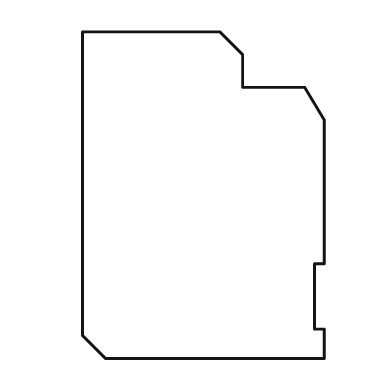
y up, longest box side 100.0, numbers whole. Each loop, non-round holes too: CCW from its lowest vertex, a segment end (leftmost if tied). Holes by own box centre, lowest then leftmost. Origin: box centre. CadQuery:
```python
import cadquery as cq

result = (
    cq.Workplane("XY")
    .moveTo(-30.0, -50.0)
    .lineTo(37.0, -50.0)
    .lineTo(37.0, -41.0)
    .lineTo(34.0, -41.0)
    .lineTo(34.0, -21.0)
    .lineTo(37.0, -21.0)
    .lineTo(37.0, 23.0)
    .lineTo(31.0, 33.0)
    .lineTo(12.0, 33.0)
    .lineTo(12.0, 43.0)
    .lineTo(5.0, 50.0)
    .lineTo(-37.0, 50.0)
    .lineTo(-37.0, -43.0)
    .close()
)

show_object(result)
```